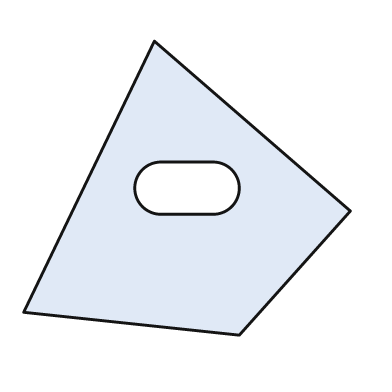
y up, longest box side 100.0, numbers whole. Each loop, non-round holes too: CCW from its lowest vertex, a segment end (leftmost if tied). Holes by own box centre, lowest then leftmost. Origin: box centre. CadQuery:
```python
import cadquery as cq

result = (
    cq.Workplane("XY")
    .moveTo(16.0, -45.0)
    .lineTo(50.0, -7.0)
    .lineTo(-10.0, 45.0)
    .lineTo(-50.0, -38.0)
    .close()
    .moveTo(-8.0, -8.0)
    .lineTo(8.0, -8.0)
    .threePointArc((16.0, 0.0), (8.0, 8.0))
    .lineTo(-8.0, 8.0)
    .threePointArc((-16.0, 0.0), (-8.0, -8.0))
    .close()
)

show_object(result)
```